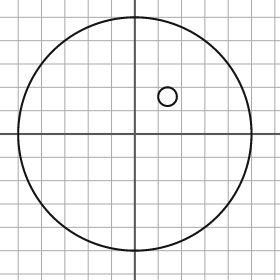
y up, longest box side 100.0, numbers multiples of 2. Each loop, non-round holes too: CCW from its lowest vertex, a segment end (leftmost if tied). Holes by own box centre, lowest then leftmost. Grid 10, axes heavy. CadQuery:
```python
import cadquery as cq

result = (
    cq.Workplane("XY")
    .moveTo(0.0, 0.0)
    .circle(50.0)
    .moveTo(14.0, 16.0)
    .circle(4.0)
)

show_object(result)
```